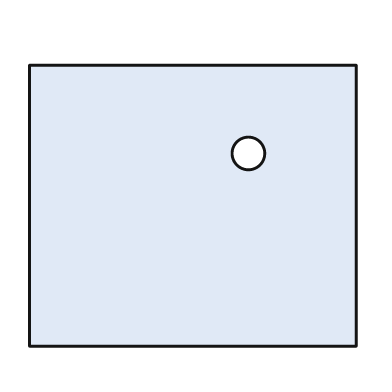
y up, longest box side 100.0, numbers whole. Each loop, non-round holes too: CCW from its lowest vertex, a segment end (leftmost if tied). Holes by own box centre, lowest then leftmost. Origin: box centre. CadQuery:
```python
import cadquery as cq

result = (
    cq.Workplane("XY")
    .moveTo(-50.0, -43.0)
    .lineTo(50.0, -43.0)
    .lineTo(50.0, 43.0)
    .lineTo(-50.0, 43.0)
    .close()
    .moveTo(17.0, 16.0)
    .circle(5.0)
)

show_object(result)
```